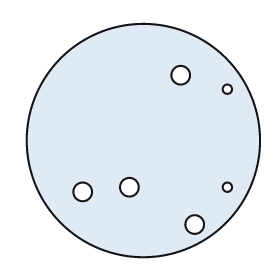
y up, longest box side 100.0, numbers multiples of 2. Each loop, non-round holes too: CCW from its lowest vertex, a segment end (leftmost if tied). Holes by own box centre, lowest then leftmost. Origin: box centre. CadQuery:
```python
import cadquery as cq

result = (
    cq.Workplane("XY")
    .moveTo(0.0, 0.0)
    .circle(50.0)
    .moveTo(22.0, -36.0)
    .circle(4.0)
    .moveTo(-26.0, -22.0)
    .circle(4.0)
    .moveTo(-6.0, -20.0)
    .circle(4.0)
    .moveTo(36.0, -20.0)
    .circle(2.0)
    .moveTo(36.0, 22.0)
    .circle(2.0)
    .moveTo(16.0, 28.0)
    .circle(4.0)
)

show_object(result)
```